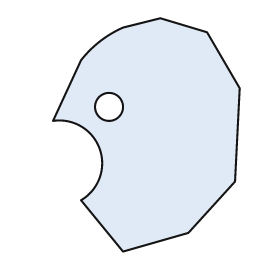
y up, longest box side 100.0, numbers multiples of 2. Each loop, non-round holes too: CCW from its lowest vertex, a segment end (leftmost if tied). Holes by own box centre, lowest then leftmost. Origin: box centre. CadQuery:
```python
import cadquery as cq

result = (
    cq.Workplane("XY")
    .moveTo(-10.0, -50.0)
    .lineTo(18.0, -42.0)
    .lineTo(38.0, -20.0)
    .lineTo(40.0, 20.0)
    .lineTo(26.0, 44.0)
    .lineTo(6.0, 50.0)
    .lineTo(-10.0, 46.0)
    .threePointArc((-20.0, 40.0), (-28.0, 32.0))
    .lineTo(-40.0, 6.0)
    .threePointArc((-20.0, -6.0), (-28.0, -28.0))
    .close()
    .moveTo(-16.0, 12.0)
    .circle(6.0)
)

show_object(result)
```